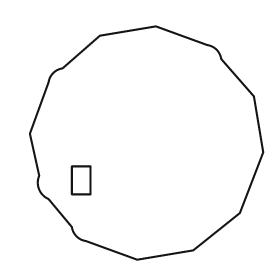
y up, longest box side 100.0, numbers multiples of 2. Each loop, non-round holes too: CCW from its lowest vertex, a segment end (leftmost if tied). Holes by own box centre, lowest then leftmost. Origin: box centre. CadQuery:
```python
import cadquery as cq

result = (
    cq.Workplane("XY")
    .moveTo(-4.0, -50.0)
    .lineTo(20.0, -46.0)
    .lineTo(40.0, -30.0)
    .lineTo(50.0, -4.0)
    .lineTo(46.0, 20.0)
    .lineTo(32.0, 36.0)
    .threePointArc((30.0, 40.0), (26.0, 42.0))
    .lineTo(4.0, 50.0)
    .lineTo(-20.0, 46.0)
    .lineTo(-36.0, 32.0)
    .threePointArc((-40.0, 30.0), (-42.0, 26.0))
    .lineTo(-50.0, 4.0)
    .lineTo(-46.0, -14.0)
    .threePointArc((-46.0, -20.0), (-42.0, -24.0))
    .lineTo(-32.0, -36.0)
    .threePointArc((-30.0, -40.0), (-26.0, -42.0))
    .close()
    .moveTo(-32.0, -22.0)
    .lineTo(-24.0, -22.0)
    .lineTo(-24.0, -10.0)
    .lineTo(-32.0, -10.0)
    .close()
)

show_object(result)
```